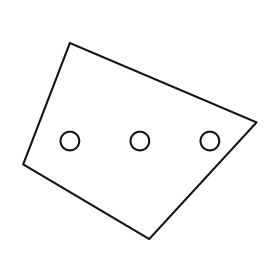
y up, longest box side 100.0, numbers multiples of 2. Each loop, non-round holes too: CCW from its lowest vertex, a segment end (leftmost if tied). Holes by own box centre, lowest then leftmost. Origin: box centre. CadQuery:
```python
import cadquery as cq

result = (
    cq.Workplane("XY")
    .moveTo(4.0, -42.0)
    .lineTo(50.0, 8.0)
    .lineTo(-30.0, 42.0)
    .lineTo(-50.0, -10.0)
    .close()
    .moveTo(-30.0, 0.0)
    .circle(4.0)
    .moveTo(0.0, 0.0)
    .circle(4.0)
    .moveTo(30.0, 0.0)
    .circle(4.0)
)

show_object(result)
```